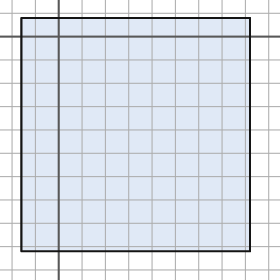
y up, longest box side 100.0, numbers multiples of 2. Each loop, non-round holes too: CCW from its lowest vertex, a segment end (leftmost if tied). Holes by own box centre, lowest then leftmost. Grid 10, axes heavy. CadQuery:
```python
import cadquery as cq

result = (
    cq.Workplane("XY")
    .moveTo(-16.0, -92.0)
    .lineTo(82.0, -92.0)
    .lineTo(82.0, 8.0)
    .lineTo(-16.0, 8.0)
    .close()
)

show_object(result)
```